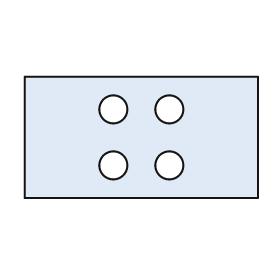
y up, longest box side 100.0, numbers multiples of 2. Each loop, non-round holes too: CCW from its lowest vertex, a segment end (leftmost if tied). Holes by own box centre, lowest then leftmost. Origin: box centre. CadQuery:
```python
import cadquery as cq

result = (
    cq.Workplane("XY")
    .moveTo(-50.0, -26.0)
    .lineTo(50.0, -26.0)
    .lineTo(50.0, 26.0)
    .lineTo(-50.0, 26.0)
    .close()
    .moveTo(-12.0, -12.0)
    .circle(6.0)
    .moveTo(12.0, -12.0)
    .circle(6.0)
    .moveTo(-12.0, 12.0)
    .circle(6.0)
    .moveTo(12.0, 12.0)
    .circle(6.0)
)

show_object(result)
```